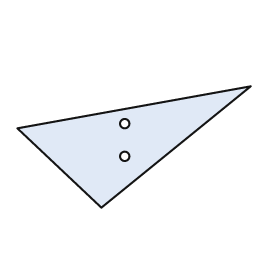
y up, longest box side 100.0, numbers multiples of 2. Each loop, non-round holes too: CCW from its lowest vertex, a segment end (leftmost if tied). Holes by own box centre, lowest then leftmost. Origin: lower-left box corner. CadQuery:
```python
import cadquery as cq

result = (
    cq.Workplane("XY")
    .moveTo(36.0, 0.0)
    .lineTo(100.0, 52.0)
    .lineTo(0.0, 34.0)
    .close()
    .moveTo(46.0, 22.0)
    .circle(2.0)
    .moveTo(46.0, 36.0)
    .circle(2.0)
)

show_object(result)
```